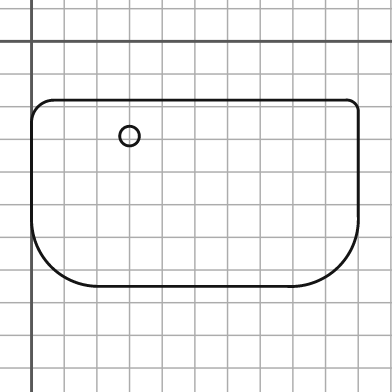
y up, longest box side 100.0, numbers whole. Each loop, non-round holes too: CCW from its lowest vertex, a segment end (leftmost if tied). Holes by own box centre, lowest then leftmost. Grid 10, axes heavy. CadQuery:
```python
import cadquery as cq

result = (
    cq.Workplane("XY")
    .moveTo(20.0, -75.0)
    .lineTo(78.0, -75.0)
    .threePointArc((94.0, -69.0), (100.0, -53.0))
    .lineTo(100.0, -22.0)
    .threePointArc((99.0, -19.0), (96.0, -18.0))
    .lineTo(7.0, -18.0)
    .threePointArc((2.0, -20.0), (0.0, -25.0))
    .lineTo(0.0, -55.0)
    .threePointArc((6.0, -69.0), (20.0, -75.0))
    .close()
    .moveTo(30.0, -29.0)
    .circle(3.0)
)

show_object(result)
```